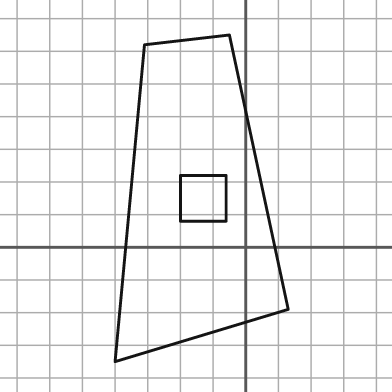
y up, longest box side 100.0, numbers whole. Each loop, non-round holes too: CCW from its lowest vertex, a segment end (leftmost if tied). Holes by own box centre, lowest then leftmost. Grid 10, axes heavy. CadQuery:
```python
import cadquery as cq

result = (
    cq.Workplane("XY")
    .moveTo(-40.0, -35.0)
    .lineTo(13.0, -19.0)
    .lineTo(-5.0, 65.0)
    .lineTo(-31.0, 62.0)
    .close()
    .moveTo(-20.0, 8.0)
    .lineTo(-6.0, 8.0)
    .lineTo(-6.0, 22.0)
    .lineTo(-20.0, 22.0)
    .close()
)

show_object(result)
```